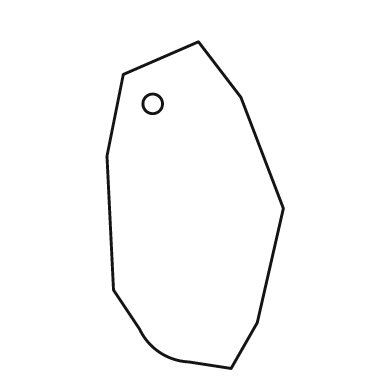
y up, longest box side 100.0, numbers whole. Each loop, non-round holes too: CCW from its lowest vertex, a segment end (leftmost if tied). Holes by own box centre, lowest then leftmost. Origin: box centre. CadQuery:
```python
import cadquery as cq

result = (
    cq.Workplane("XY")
    .moveTo(11.0, -50.0)
    .lineTo(19.0, -36.0)
    .lineTo(27.0, -1.0)
    .lineTo(14.0, 33.0)
    .lineTo(1.0, 50.0)
    .lineTo(-22.0, 40.0)
    .lineTo(-27.0, 15.0)
    .lineTo(-25.0, -26.0)
    .lineTo(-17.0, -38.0)
    .threePointArc((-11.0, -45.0), (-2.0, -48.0))
    .close()
    .moveTo(-13.0, 31.0)
    .circle(3.0)
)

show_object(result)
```